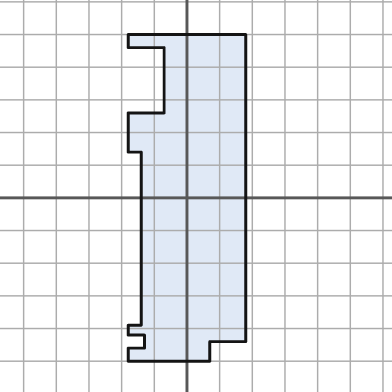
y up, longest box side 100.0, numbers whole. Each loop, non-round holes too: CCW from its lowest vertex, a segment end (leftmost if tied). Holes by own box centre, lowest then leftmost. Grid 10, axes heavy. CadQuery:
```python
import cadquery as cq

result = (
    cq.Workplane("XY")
    .moveTo(-18.0, -50.0)
    .lineTo(7.0, -50.0)
    .lineTo(7.0, -44.0)
    .lineTo(18.0, -44.0)
    .lineTo(18.0, 50.0)
    .lineTo(-18.0, 50.0)
    .lineTo(-18.0, 46.0)
    .lineTo(-7.0, 46.0)
    .lineTo(-7.0, 26.0)
    .lineTo(-18.0, 26.0)
    .lineTo(-18.0, 14.0)
    .lineTo(-14.0, 14.0)
    .lineTo(-14.0, -39.0)
    .lineTo(-18.0, -39.0)
    .lineTo(-18.0, -42.0)
    .lineTo(-13.0, -42.0)
    .lineTo(-13.0, -46.0)
    .lineTo(-18.0, -46.0)
    .close()
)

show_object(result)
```